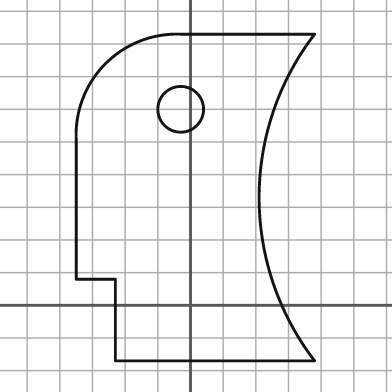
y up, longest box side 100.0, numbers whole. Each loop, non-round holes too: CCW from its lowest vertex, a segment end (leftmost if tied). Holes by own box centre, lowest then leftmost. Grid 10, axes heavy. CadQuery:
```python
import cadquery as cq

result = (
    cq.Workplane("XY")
    .moveTo(-23.0, -17.0)
    .lineTo(38.0, -17.0)
    .threePointArc((21.0, 33.0), (38.0, 83.0))
    .lineTo(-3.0, 83.0)
    .threePointArc((-26.0, 74.0), (-35.0, 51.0))
    .lineTo(-35.0, 8.0)
    .lineTo(-23.0, 8.0)
    .close()
    .moveTo(-3.0, 60.0)
    .circle(7.0)
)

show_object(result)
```